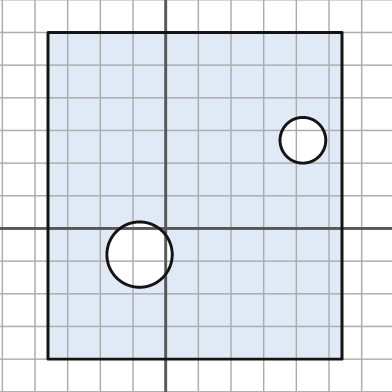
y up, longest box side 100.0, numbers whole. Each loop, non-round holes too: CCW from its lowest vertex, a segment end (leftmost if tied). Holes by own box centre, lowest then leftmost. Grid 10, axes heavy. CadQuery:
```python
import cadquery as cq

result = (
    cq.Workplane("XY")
    .moveTo(-36.0, -40.0)
    .lineTo(54.0, -40.0)
    .lineTo(54.0, 60.0)
    .lineTo(-36.0, 60.0)
    .close()
    .moveTo(-8.0, -8.0)
    .circle(10.0)
    .moveTo(42.0, 27.0)
    .circle(7.0)
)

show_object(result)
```